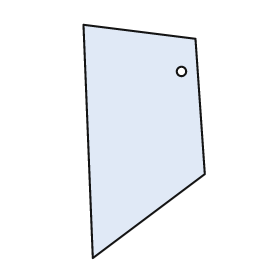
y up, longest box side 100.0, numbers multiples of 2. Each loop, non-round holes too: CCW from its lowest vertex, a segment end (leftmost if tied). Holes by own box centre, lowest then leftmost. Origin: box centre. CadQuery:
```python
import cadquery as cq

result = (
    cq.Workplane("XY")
    .moveTo(-22.0, -50.0)
    .lineTo(26.0, -14.0)
    .lineTo(22.0, 44.0)
    .lineTo(-26.0, 50.0)
    .close()
    .moveTo(16.0, 30.0)
    .circle(2.0)
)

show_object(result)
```